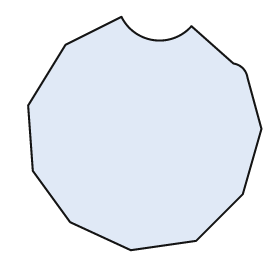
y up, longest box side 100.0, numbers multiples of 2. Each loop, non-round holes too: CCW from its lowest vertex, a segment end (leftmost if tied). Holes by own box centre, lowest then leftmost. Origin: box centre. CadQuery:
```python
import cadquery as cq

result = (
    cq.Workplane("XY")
    .moveTo(-6.0, -50.0)
    .lineTo(22.0, -46.0)
    .lineTo(42.0, -26.0)
    .lineTo(50.0, 2.0)
    .lineTo(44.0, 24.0)
    .threePointArc((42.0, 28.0), (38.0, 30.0))
    .lineTo(20.0, 46.0)
    .threePointArc((4.0, 40.0), (-10.0, 50.0))
    .lineTo(-34.0, 38.0)
    .lineTo(-50.0, 12.0)
    .lineTo(-48.0, -16.0)
    .lineTo(-32.0, -38.0)
    .close()
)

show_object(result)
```